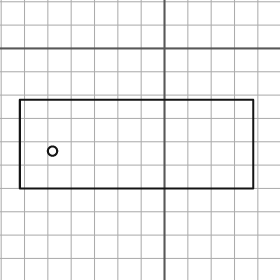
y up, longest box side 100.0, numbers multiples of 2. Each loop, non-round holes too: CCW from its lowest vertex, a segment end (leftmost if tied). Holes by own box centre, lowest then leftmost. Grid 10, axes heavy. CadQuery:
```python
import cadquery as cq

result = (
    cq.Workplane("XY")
    .moveTo(-62.0, -60.0)
    .lineTo(38.0, -60.0)
    .lineTo(38.0, -22.0)
    .lineTo(-62.0, -22.0)
    .close()
    .moveTo(-48.0, -44.0)
    .circle(2.0)
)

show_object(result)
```